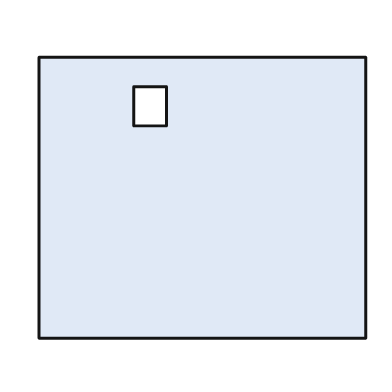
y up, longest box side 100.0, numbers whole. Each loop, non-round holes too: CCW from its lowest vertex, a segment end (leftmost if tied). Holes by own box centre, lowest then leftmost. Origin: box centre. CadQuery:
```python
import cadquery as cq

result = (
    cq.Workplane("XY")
    .moveTo(-50.0, -43.0)
    .lineTo(50.0, -43.0)
    .lineTo(50.0, 43.0)
    .lineTo(-50.0, 43.0)
    .close()
    .moveTo(-21.0, 22.0)
    .lineTo(-11.0, 22.0)
    .lineTo(-11.0, 34.0)
    .lineTo(-21.0, 34.0)
    .close()
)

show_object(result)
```